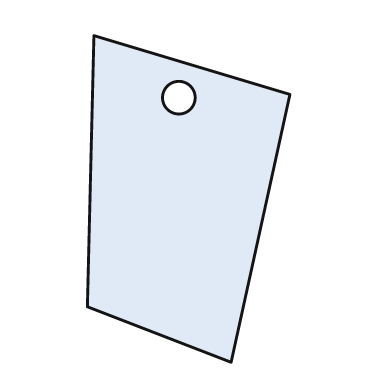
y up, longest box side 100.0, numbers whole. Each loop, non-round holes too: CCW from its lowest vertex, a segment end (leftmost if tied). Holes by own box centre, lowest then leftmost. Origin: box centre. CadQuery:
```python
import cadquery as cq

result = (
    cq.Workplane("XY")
    .moveTo(13.0, -50.0)
    .lineTo(31.0, 32.0)
    .lineTo(-29.0, 50.0)
    .lineTo(-31.0, -33.0)
    .close()
    .moveTo(-3.0, 31.0)
    .circle(5.0)
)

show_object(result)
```